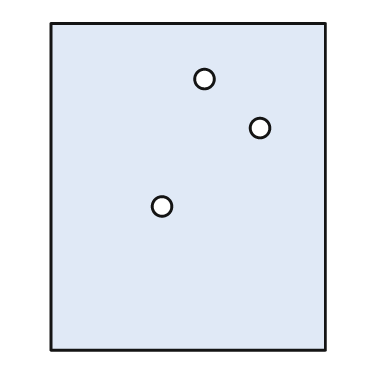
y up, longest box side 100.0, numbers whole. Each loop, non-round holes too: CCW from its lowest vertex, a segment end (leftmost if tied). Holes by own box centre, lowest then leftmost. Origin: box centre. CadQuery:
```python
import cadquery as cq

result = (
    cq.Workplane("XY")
    .moveTo(-42.0, -50.0)
    .lineTo(42.0, -50.0)
    .lineTo(42.0, 50.0)
    .lineTo(-42.0, 50.0)
    .close()
    .moveTo(-8.0, -6.0)
    .circle(3.0)
    .moveTo(22.0, 18.0)
    .circle(3.0)
    .moveTo(5.0, 33.0)
    .circle(3.0)
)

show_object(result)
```